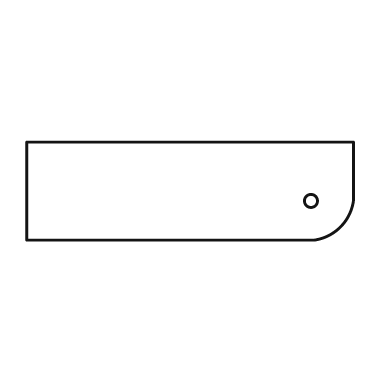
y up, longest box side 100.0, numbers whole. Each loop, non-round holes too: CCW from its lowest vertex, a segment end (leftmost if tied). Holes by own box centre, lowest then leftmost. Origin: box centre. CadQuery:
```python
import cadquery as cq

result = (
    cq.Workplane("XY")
    .moveTo(-50.0, -15.0)
    .lineTo(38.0, -15.0)
    .threePointArc((46.0, -11.0), (50.0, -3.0))
    .lineTo(50.0, 15.0)
    .lineTo(-50.0, 15.0)
    .close()
    .moveTo(37.0, -3.0)
    .circle(2.0)
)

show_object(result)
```